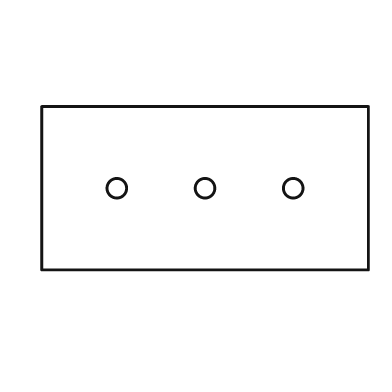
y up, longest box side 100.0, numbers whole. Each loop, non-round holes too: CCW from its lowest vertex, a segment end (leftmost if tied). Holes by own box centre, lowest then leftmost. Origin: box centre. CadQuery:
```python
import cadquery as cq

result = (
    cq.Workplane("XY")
    .moveTo(-50.0, -25.0)
    .lineTo(50.0, -25.0)
    .lineTo(50.0, 25.0)
    .lineTo(-50.0, 25.0)
    .close()
    .moveTo(-27.0, 0.0)
    .circle(3.0)
    .moveTo(0.0, 0.0)
    .circle(3.0)
    .moveTo(27.0, 0.0)
    .circle(3.0)
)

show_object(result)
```